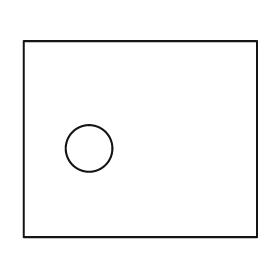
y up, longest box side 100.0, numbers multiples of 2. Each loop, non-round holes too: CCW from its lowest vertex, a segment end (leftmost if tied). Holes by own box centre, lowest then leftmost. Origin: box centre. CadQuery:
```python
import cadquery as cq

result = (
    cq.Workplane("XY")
    .moveTo(-50.0, -42.0)
    .lineTo(50.0, -42.0)
    .lineTo(50.0, 42.0)
    .lineTo(-50.0, 42.0)
    .close()
    .moveTo(-22.0, -4.0)
    .circle(10.0)
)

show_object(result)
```